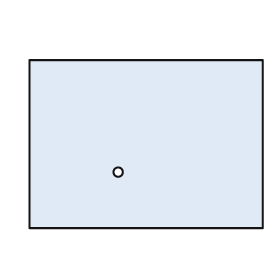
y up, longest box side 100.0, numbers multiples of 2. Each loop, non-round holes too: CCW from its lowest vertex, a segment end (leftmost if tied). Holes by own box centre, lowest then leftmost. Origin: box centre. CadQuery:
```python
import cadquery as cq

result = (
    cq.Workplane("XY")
    .moveTo(-50.0, -36.0)
    .lineTo(50.0, -36.0)
    .lineTo(50.0, 36.0)
    .lineTo(-50.0, 36.0)
    .close()
    .moveTo(-12.0, -12.0)
    .circle(2.0)
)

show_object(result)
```